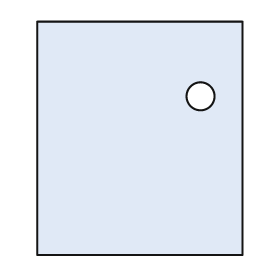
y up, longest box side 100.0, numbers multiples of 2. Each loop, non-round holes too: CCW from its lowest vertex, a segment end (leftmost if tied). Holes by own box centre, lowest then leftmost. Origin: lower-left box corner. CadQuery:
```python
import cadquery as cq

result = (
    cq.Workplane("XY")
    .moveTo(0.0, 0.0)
    .lineTo(88.0, 0.0)
    .lineTo(88.0, 100.0)
    .lineTo(0.0, 100.0)
    .close()
    .moveTo(70.0, 68.0)
    .circle(6.0)
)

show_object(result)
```